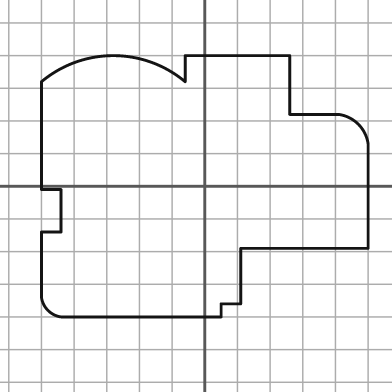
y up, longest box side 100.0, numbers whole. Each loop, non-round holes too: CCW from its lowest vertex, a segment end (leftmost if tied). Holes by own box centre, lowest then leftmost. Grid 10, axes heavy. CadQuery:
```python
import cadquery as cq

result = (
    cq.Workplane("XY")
    .moveTo(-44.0, -40.0)
    .lineTo(5.0, -40.0)
    .lineTo(5.0, -36.0)
    .lineTo(11.0, -36.0)
    .lineTo(11.0, -19.0)
    .lineTo(50.0, -19.0)
    .lineTo(50.0, 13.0)
    .threePointArc((47.0, 19.0), (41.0, 22.0))
    .lineTo(26.0, 22.0)
    .lineTo(26.0, 40.0)
    .lineTo(-6.0, 40.0)
    .lineTo(-6.0, 32.0)
    .threePointArc((-28.0, 40.0), (-50.0, 32.0))
    .lineTo(-50.0, -1.0)
    .lineTo(-44.0, -1.0)
    .lineTo(-44.0, -14.0)
    .lineTo(-50.0, -14.0)
    .lineTo(-50.0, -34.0)
    .threePointArc((-48.0, -38.0), (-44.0, -40.0))
    .close()
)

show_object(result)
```